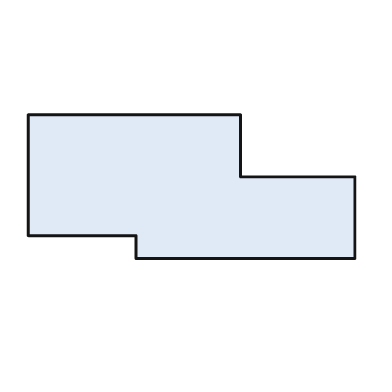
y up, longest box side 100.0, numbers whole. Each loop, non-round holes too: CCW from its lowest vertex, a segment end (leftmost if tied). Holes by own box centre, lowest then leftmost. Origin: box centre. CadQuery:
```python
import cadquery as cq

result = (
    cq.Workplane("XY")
    .moveTo(-17.0, -22.0)
    .lineTo(50.0, -22.0)
    .lineTo(50.0, 3.0)
    .lineTo(15.0, 3.0)
    .lineTo(15.0, 22.0)
    .lineTo(-50.0, 22.0)
    .lineTo(-50.0, -15.0)
    .lineTo(-17.0, -15.0)
    .close()
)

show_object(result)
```